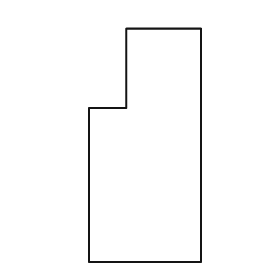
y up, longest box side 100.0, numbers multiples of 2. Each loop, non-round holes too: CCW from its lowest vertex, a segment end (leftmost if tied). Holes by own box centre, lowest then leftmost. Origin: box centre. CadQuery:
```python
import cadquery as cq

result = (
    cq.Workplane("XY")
    .moveTo(-24.0, -50.0)
    .lineTo(24.0, -50.0)
    .lineTo(24.0, 50.0)
    .lineTo(-8.0, 50.0)
    .lineTo(-8.0, 16.0)
    .lineTo(-24.0, 16.0)
    .close()
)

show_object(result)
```